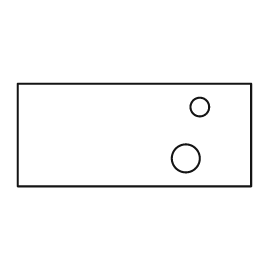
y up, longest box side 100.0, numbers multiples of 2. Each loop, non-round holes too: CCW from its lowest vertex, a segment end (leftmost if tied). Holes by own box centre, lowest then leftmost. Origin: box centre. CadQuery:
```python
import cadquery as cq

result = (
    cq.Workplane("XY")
    .moveTo(-50.0, -22.0)
    .lineTo(50.0, -22.0)
    .lineTo(50.0, 22.0)
    .lineTo(-50.0, 22.0)
    .close()
    .moveTo(22.0, -10.0)
    .circle(6.0)
    .moveTo(28.0, 12.0)
    .circle(4.0)
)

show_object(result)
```